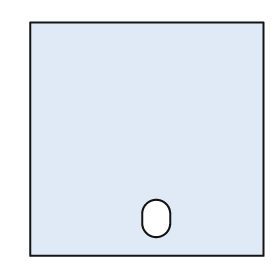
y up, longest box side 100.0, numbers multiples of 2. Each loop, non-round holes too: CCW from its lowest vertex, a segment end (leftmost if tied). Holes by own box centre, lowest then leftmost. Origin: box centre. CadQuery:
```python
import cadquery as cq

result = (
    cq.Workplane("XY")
    .moveTo(-50.0, -50.0)
    .lineTo(50.0, -50.0)
    .lineTo(50.0, 50.0)
    .lineTo(-50.0, 50.0)
    .close()
    .moveTo(-2.0, -36.0)
    .threePointArc((4.0, -42.0), (10.0, -36.0))
    .lineTo(10.0, -32.0)
    .threePointArc((4.0, -26.0), (-2.0, -32.0))
    .close()
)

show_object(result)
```